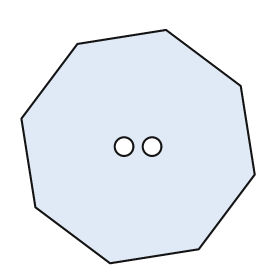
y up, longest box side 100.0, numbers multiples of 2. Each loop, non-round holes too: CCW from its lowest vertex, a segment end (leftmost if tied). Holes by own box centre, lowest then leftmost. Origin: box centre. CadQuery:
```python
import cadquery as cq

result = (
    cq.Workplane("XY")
    .moveTo(-12.0, -50.0)
    .lineTo(26.0, -44.0)
    .lineTo(50.0, -12.0)
    .lineTo(44.0, 26.0)
    .lineTo(12.0, 50.0)
    .lineTo(-26.0, 44.0)
    .lineTo(-50.0, 12.0)
    .lineTo(-44.0, -26.0)
    .close()
    .moveTo(-6.0, 0.0)
    .circle(4.0)
    .moveTo(6.0, 0.0)
    .circle(4.0)
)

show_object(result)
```